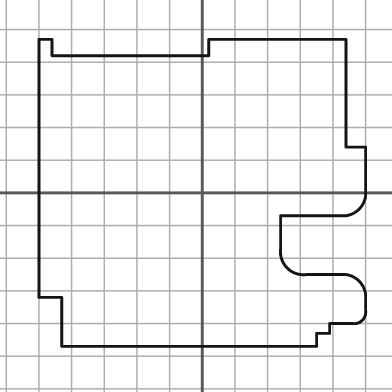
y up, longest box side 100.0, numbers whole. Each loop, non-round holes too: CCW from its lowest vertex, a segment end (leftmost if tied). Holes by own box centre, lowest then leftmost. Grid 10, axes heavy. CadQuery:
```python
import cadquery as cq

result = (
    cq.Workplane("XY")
    .moveTo(-43.0, -47.0)
    .lineTo(35.0, -47.0)
    .lineTo(35.0, -43.0)
    .lineTo(39.0, -43.0)
    .lineTo(39.0, -40.0)
    .lineTo(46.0, -40.0)
    .threePointArc((49.0, -39.0), (50.0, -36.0))
    .lineTo(50.0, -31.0)
    .threePointArc((48.0, -27.0), (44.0, -25.0))
    .lineTo(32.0, -25.0)
    .threePointArc((26.0, -23.0), (24.0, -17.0))
    .lineTo(24.0, -7.0)
    .lineTo(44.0, -7.0)
    .threePointArc((48.0, -5.0), (50.0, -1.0))
    .lineTo(50.0, 14.0)
    .lineTo(44.0, 14.0)
    .lineTo(44.0, 47.0)
    .lineTo(2.0, 47.0)
    .lineTo(2.0, 42.0)
    .lineTo(-46.0, 42.0)
    .lineTo(-46.0, 47.0)
    .lineTo(-50.0, 47.0)
    .lineTo(-50.0, -32.0)
    .lineTo(-43.0, -32.0)
    .close()
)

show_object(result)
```